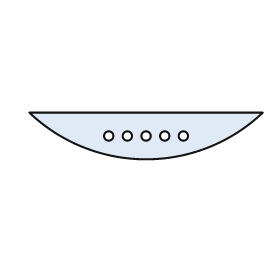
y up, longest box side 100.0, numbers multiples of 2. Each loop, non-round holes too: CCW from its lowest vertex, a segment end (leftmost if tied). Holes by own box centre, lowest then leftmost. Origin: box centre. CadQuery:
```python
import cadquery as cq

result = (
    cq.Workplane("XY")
    .moveTo(-50.0, 10.0)
    .threePointArc((0.0, -10.0), (50.0, 10.0))
    .close()
    .moveTo(-16.0, 0.0)
    .circle(2.0)
    .moveTo(-8.0, 0.0)
    .circle(2.0)
    .moveTo(0.0, 0.0)
    .circle(2.0)
    .moveTo(8.0, 0.0)
    .circle(2.0)
    .moveTo(16.0, 0.0)
    .circle(2.0)
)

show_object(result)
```